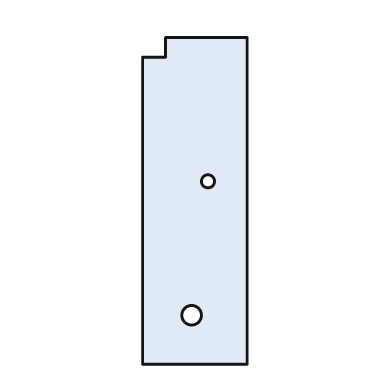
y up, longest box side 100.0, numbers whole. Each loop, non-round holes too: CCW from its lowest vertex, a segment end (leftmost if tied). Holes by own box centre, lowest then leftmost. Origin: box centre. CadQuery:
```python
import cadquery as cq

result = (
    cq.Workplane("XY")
    .moveTo(-16.0, -50.0)
    .lineTo(16.0, -50.0)
    .lineTo(16.0, 50.0)
    .lineTo(-9.0, 50.0)
    .lineTo(-9.0, 44.0)
    .lineTo(-16.0, 44.0)
    .close()
    .moveTo(-1.0, -35.0)
    .circle(3.0)
    .moveTo(4.0, 6.0)
    .circle(2.0)
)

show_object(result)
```